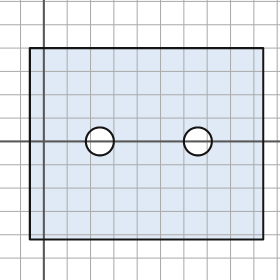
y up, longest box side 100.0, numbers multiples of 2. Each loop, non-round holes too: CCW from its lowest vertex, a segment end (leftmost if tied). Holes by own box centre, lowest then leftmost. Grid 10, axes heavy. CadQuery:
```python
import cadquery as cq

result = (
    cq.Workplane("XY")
    .moveTo(-6.0, -42.0)
    .lineTo(94.0, -42.0)
    .lineTo(94.0, 40.0)
    .lineTo(-6.0, 40.0)
    .close()
    .moveTo(24.0, 0.0)
    .circle(6.0)
    .moveTo(66.0, 0.0)
    .circle(6.0)
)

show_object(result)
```